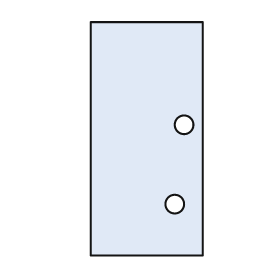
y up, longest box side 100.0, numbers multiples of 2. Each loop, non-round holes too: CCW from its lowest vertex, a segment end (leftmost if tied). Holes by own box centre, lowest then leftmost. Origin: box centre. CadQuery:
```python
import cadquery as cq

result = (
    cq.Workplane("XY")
    .moveTo(-24.0, -50.0)
    .lineTo(24.0, -50.0)
    .lineTo(24.0, 50.0)
    .lineTo(-24.0, 50.0)
    .close()
    .moveTo(12.0, -28.0)
    .circle(4.0)
    .moveTo(16.0, 6.0)
    .circle(4.0)
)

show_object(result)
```